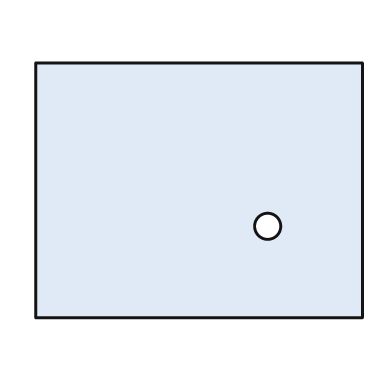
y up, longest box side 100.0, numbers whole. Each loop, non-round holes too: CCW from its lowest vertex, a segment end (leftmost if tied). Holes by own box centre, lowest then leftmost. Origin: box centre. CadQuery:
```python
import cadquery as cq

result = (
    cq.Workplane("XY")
    .moveTo(-50.0, -39.0)
    .lineTo(50.0, -39.0)
    .lineTo(50.0, 39.0)
    .lineTo(-50.0, 39.0)
    .close()
    .moveTo(21.0, -11.0)
    .circle(4.0)
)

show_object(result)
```